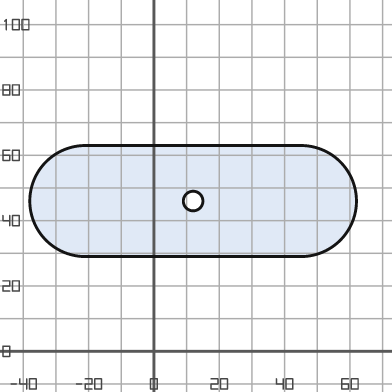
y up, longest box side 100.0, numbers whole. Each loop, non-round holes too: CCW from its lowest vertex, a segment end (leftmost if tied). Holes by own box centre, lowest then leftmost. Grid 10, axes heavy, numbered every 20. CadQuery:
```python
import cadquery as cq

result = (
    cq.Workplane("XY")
    .moveTo(-21.0, 29.0)
    .lineTo(45.0, 29.0)
    .threePointArc((62.0, 46.0), (45.0, 63.0))
    .lineTo(-21.0, 63.0)
    .threePointArc((-38.0, 46.0), (-21.0, 29.0))
    .close()
    .moveTo(12.0, 46.0)
    .circle(3.0)
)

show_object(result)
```